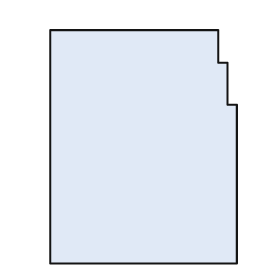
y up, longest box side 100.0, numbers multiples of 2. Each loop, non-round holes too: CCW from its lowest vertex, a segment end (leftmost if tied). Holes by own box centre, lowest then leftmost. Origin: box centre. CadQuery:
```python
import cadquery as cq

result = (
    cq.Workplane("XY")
    .moveTo(-40.0, -50.0)
    .lineTo(40.0, -50.0)
    .lineTo(40.0, 18.0)
    .lineTo(36.0, 18.0)
    .lineTo(36.0, 36.0)
    .lineTo(32.0, 36.0)
    .lineTo(32.0, 50.0)
    .lineTo(-40.0, 50.0)
    .close()
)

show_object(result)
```